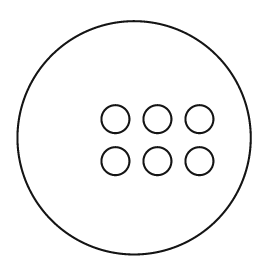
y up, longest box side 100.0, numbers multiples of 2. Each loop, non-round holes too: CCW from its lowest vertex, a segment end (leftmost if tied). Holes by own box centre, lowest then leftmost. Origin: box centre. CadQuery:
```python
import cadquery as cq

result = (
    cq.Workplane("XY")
    .moveTo(0.0, 0.0)
    .circle(50.0)
    .moveTo(-8.0, -10.0)
    .circle(6.0)
    .moveTo(10.0, -10.0)
    .circle(6.0)
    .moveTo(28.0, -10.0)
    .circle(6.0)
    .moveTo(-8.0, 8.0)
    .circle(6.0)
    .moveTo(10.0, 8.0)
    .circle(6.0)
    .moveTo(28.0, 8.0)
    .circle(6.0)
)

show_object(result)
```